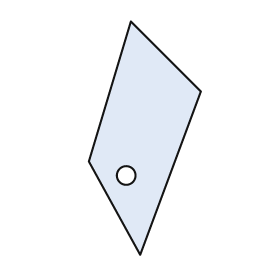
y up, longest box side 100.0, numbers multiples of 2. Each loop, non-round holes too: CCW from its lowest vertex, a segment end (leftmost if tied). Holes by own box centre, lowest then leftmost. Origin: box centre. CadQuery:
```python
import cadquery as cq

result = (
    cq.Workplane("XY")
    .moveTo(-2.0, -50.0)
    .lineTo(24.0, 20.0)
    .lineTo(-6.0, 50.0)
    .lineTo(-24.0, -10.0)
    .close()
    .moveTo(-8.0, -16.0)
    .circle(4.0)
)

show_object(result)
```